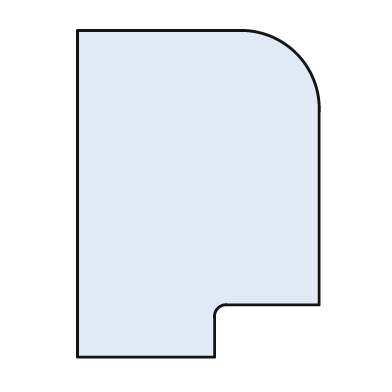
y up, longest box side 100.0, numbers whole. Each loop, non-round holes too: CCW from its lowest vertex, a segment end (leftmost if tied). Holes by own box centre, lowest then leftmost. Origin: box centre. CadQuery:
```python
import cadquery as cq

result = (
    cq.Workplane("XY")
    .moveTo(-37.0, -50.0)
    .lineTo(5.0, -50.0)
    .lineTo(5.0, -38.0)
    .threePointArc((6.0, -35.0), (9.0, -34.0))
    .lineTo(37.0, -34.0)
    .lineTo(37.0, 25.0)
    .threePointArc((30.0, 43.0), (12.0, 50.0))
    .lineTo(-37.0, 50.0)
    .close()
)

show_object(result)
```